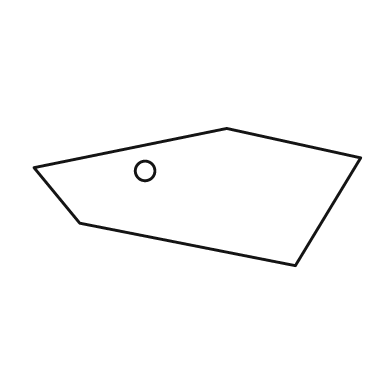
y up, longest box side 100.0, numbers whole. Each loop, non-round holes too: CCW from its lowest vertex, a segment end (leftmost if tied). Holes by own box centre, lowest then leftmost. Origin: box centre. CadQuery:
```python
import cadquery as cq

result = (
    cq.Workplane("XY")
    .moveTo(30.0, -21.0)
    .lineTo(50.0, 12.0)
    .lineTo(9.0, 21.0)
    .lineTo(-50.0, 9.0)
    .lineTo(-36.0, -8.0)
    .close()
    .moveTo(-16.0, 8.0)
    .circle(3.0)
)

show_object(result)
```